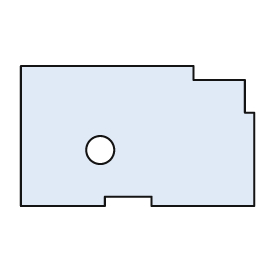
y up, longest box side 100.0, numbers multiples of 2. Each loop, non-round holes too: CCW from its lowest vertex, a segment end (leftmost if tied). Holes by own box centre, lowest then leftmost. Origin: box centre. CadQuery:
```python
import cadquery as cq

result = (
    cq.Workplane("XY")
    .moveTo(-50.0, -30.0)
    .lineTo(-14.0, -30.0)
    .lineTo(-14.0, -26.0)
    .lineTo(6.0, -26.0)
    .lineTo(6.0, -30.0)
    .lineTo(50.0, -30.0)
    .lineTo(50.0, 10.0)
    .lineTo(46.0, 10.0)
    .lineTo(46.0, 24.0)
    .lineTo(24.0, 24.0)
    .lineTo(24.0, 30.0)
    .lineTo(-50.0, 30.0)
    .close()
    .moveTo(-16.0, -6.0)
    .circle(6.0)
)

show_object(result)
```